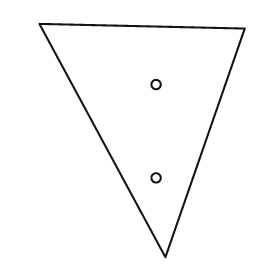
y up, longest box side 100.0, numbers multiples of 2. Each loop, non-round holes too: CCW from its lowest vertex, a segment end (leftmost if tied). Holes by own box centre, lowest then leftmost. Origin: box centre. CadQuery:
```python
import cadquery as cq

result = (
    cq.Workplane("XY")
    .moveTo(10.0, -50.0)
    .lineTo(44.0, 48.0)
    .lineTo(-44.0, 50.0)
    .close()
    .moveTo(6.0, -16.0)
    .circle(2.0)
    .moveTo(6.0, 24.0)
    .circle(2.0)
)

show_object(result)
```